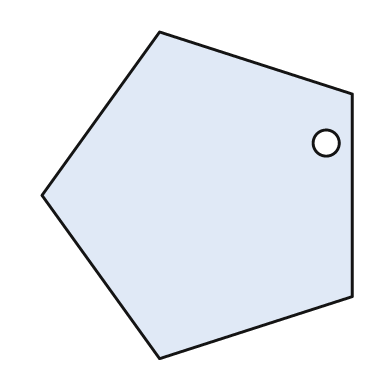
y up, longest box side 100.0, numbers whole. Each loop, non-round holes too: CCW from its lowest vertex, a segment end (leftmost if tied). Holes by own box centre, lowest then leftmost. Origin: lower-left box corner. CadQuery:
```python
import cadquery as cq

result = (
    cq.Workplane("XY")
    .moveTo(36.0, 0.0)
    .lineTo(95.0, 19.0)
    .lineTo(95.0, 81.0)
    .lineTo(36.0, 100.0)
    .lineTo(0.0, 50.0)
    .close()
    .moveTo(87.0, 66.0)
    .circle(4.0)
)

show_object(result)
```